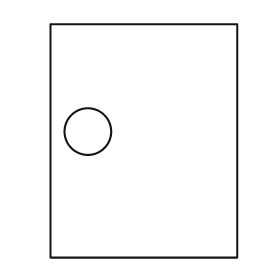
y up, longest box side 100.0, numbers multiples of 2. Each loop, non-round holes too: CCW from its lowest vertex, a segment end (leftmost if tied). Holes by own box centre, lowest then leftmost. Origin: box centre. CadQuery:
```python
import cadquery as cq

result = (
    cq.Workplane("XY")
    .moveTo(-40.0, -50.0)
    .lineTo(40.0, -50.0)
    .lineTo(40.0, 50.0)
    .lineTo(-40.0, 50.0)
    .close()
    .moveTo(-24.0, 4.0)
    .circle(10.0)
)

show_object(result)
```